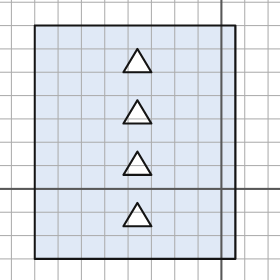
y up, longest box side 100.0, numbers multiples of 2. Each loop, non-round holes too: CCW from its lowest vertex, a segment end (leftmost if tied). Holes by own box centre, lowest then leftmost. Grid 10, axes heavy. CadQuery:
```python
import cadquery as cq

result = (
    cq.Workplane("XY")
    .moveTo(-80.0, -30.0)
    .lineTo(6.0, -30.0)
    .lineTo(6.0, 70.0)
    .lineTo(-80.0, 70.0)
    .close()
    .moveTo(-42.0, -16.0)
    .lineTo(-30.0, -16.0)
    .lineTo(-36.0, -6.0)
    .close()
    .moveTo(-42.0, 6.0)
    .lineTo(-30.0, 6.0)
    .lineTo(-36.0, 16.0)
    .close()
    .moveTo(-42.0, 28.0)
    .lineTo(-30.0, 28.0)
    .lineTo(-36.0, 38.0)
    .close()
    .moveTo(-42.0, 50.0)
    .lineTo(-30.0, 50.0)
    .lineTo(-36.0, 60.0)
    .close()
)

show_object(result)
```